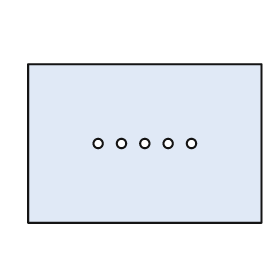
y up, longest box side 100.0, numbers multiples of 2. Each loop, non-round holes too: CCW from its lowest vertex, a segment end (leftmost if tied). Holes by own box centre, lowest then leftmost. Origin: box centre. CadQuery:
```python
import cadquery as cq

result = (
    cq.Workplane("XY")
    .moveTo(-50.0, -34.0)
    .lineTo(50.0, -34.0)
    .lineTo(50.0, 34.0)
    .lineTo(-50.0, 34.0)
    .close()
    .moveTo(-20.0, 0.0)
    .circle(2.0)
    .moveTo(-10.0, 0.0)
    .circle(2.0)
    .moveTo(0.0, 0.0)
    .circle(2.0)
    .moveTo(10.0, 0.0)
    .circle(2.0)
    .moveTo(20.0, 0.0)
    .circle(2.0)
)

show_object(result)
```